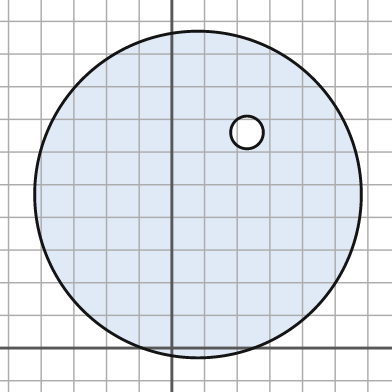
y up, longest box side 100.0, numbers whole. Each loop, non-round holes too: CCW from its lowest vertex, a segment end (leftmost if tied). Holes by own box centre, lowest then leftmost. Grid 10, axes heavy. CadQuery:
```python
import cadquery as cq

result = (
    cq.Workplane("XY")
    .moveTo(8.0, 47.0)
    .circle(50.0)
    .moveTo(23.0, 66.0)
    .circle(5.0)
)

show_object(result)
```